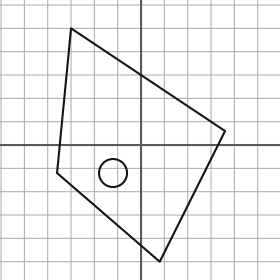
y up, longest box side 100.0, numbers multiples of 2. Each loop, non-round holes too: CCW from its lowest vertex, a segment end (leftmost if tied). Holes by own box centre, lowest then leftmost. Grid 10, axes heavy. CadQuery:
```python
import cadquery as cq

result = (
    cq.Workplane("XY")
    .moveTo(8.0, -50.0)
    .lineTo(36.0, 6.0)
    .lineTo(-30.0, 50.0)
    .lineTo(-36.0, -12.0)
    .close()
    .moveTo(-12.0, -12.0)
    .circle(6.0)
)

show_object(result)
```